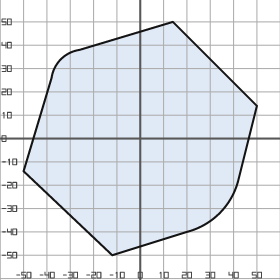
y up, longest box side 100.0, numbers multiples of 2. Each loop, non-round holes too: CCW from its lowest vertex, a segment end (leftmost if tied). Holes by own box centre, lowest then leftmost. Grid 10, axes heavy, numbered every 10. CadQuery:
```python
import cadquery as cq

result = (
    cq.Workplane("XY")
    .moveTo(-12.0, -50.0)
    .lineTo(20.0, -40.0)
    .threePointArc((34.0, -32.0), (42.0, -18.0))
    .lineTo(50.0, 14.0)
    .lineTo(14.0, 50.0)
    .lineTo(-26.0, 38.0)
    .threePointArc((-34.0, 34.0), (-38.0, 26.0))
    .lineTo(-50.0, -14.0)
    .close()
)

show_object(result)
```